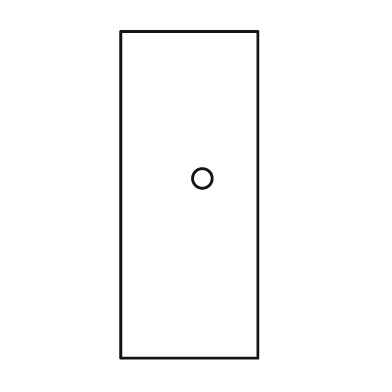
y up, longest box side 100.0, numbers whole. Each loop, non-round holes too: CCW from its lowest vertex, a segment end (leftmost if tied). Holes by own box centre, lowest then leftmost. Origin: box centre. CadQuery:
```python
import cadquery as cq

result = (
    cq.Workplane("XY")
    .moveTo(-21.0, -50.0)
    .lineTo(21.0, -50.0)
    .lineTo(21.0, 50.0)
    .lineTo(-21.0, 50.0)
    .close()
    .moveTo(4.0, 5.0)
    .circle(3.0)
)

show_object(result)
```